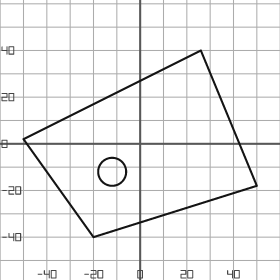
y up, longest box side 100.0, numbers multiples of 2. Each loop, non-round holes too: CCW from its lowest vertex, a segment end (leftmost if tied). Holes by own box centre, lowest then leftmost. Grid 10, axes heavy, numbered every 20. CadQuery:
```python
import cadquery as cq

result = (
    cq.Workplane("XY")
    .moveTo(-20.0, -40.0)
    .lineTo(50.0, -18.0)
    .lineTo(26.0, 40.0)
    .lineTo(-50.0, 2.0)
    .close()
    .moveTo(-12.0, -12.0)
    .circle(6.0)
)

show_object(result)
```